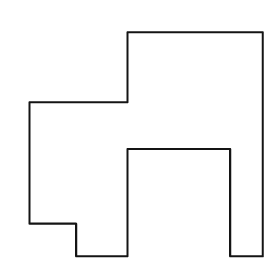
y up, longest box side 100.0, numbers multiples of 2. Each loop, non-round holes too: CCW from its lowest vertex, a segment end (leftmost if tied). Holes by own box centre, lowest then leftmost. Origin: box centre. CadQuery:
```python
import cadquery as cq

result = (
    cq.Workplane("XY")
    .moveTo(-30.0, -48.0)
    .lineTo(-8.0, -48.0)
    .lineTo(-8.0, -2.0)
    .lineTo(36.0, -2.0)
    .lineTo(36.0, -48.0)
    .lineTo(50.0, -48.0)
    .lineTo(50.0, 48.0)
    .lineTo(-8.0, 48.0)
    .lineTo(-8.0, 18.0)
    .lineTo(-50.0, 18.0)
    .lineTo(-50.0, -34.0)
    .lineTo(-30.0, -34.0)
    .close()
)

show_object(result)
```